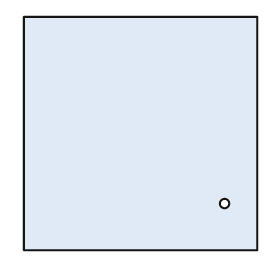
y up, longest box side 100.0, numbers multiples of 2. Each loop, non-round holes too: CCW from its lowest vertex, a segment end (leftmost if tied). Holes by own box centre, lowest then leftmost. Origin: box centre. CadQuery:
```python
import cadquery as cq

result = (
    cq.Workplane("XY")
    .moveTo(-50.0, -50.0)
    .lineTo(50.0, -50.0)
    .lineTo(50.0, 50.0)
    .lineTo(-50.0, 50.0)
    .close()
    .moveTo(36.0, -30.0)
    .circle(2.0)
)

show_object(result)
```